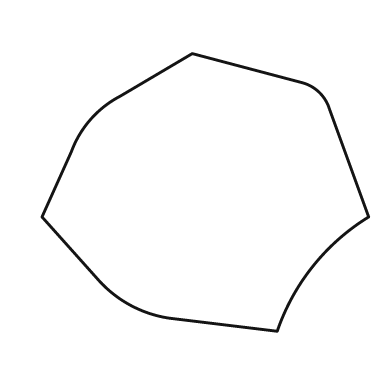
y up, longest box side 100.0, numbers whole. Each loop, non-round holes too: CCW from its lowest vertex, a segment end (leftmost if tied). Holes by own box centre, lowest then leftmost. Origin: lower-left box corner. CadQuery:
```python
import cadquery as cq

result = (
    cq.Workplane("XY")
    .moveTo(72.0, 0.0)
    .threePointArc((83.0, 20.0), (100.0, 35.0))
    .lineTo(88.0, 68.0)
    .threePointArc((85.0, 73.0), (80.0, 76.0))
    .lineTo(46.0, 85.0)
    .lineTo(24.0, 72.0)
    .threePointArc((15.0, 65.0), (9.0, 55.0))
    .lineTo(0.0, 35.0)
    .lineTo(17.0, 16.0)
    .threePointArc((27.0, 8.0), (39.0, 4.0))
    .close()
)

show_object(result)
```